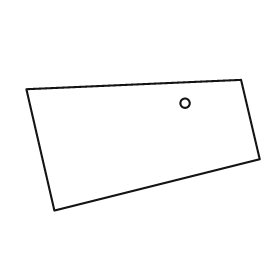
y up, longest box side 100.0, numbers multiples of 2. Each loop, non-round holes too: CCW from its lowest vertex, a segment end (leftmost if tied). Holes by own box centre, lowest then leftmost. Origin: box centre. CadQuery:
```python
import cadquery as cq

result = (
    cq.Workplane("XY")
    .moveTo(-38.0, -28.0)
    .lineTo(50.0, -6.0)
    .lineTo(42.0, 28.0)
    .lineTo(-50.0, 24.0)
    .close()
    .moveTo(18.0, 18.0)
    .circle(2.0)
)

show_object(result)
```